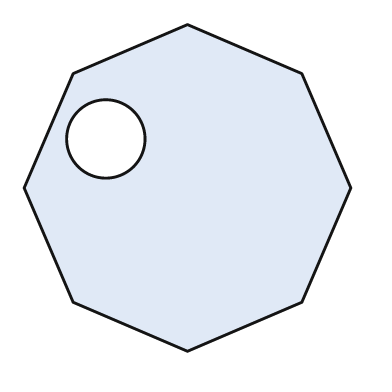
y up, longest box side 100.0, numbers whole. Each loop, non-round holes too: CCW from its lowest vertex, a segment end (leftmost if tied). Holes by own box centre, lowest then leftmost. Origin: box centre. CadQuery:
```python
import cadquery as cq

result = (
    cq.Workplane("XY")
    .moveTo(0.0, -50.0)
    .lineTo(35.0, -35.0)
    .lineTo(50.0, 0.0)
    .lineTo(35.0, 35.0)
    .lineTo(0.0, 50.0)
    .lineTo(-35.0, 35.0)
    .lineTo(-50.0, 0.0)
    .lineTo(-35.0, -35.0)
    .close()
    .moveTo(-25.0, 15.0)
    .circle(12.0)
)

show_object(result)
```